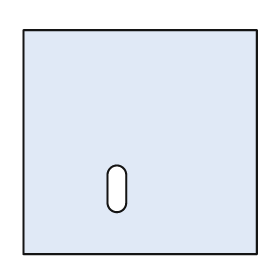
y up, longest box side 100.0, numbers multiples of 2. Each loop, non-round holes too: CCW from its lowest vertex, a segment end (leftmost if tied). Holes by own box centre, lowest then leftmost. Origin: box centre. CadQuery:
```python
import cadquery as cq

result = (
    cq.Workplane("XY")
    .moveTo(-50.0, -48.0)
    .lineTo(50.0, -48.0)
    .lineTo(50.0, 48.0)
    .lineTo(-50.0, 48.0)
    .close()
    .moveTo(-14.0, -26.0)
    .threePointArc((-10.0, -30.0), (-6.0, -26.0))
    .lineTo(-6.0, -14.0)
    .threePointArc((-10.0, -10.0), (-14.0, -14.0))
    .close()
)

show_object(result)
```